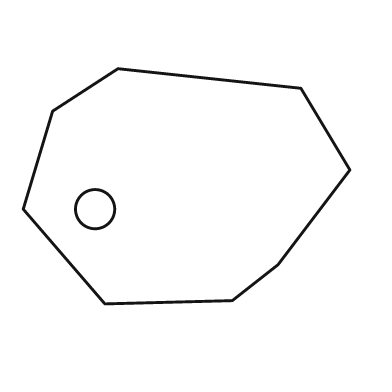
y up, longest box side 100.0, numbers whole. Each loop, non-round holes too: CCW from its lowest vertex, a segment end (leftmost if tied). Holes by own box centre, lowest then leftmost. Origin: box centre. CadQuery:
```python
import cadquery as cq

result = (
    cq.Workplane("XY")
    .moveTo(-25.0, -36.0)
    .lineTo(14.0, -35.0)
    .lineTo(28.0, -24.0)
    .lineTo(50.0, 5.0)
    .lineTo(35.0, 30.0)
    .lineTo(-21.0, 36.0)
    .lineTo(-41.0, 23.0)
    .lineTo(-50.0, -7.0)
    .close()
    .moveTo(-28.0, -7.0)
    .circle(6.0)
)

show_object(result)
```